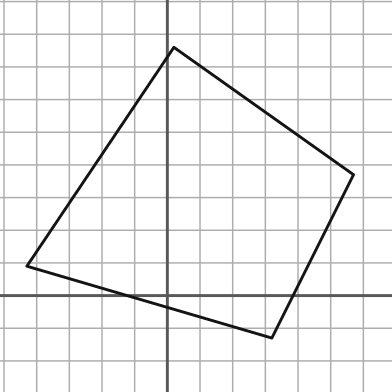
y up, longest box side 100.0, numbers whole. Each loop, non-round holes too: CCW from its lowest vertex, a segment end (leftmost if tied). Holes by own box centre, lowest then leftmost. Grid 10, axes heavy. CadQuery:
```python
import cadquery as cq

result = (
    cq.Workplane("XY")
    .moveTo(32.0, -13.0)
    .lineTo(57.0, 37.0)
    .lineTo(2.0, 76.0)
    .lineTo(-43.0, 9.0)
    .close()
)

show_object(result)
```